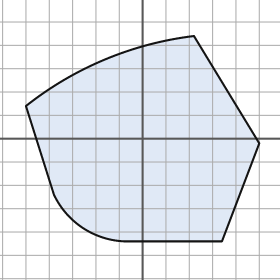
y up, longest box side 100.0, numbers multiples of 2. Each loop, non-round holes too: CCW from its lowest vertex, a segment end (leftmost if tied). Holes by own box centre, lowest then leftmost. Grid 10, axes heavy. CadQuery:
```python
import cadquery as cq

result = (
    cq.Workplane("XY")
    .moveTo(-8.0, -44.0)
    .lineTo(34.0, -44.0)
    .lineTo(50.0, -2.0)
    .lineTo(22.0, 44.0)
    .threePointArc((-16.0, 34.0), (-50.0, 14.0))
    .lineTo(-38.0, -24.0)
    .threePointArc((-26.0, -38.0), (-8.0, -44.0))
    .close()
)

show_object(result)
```